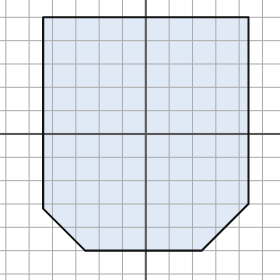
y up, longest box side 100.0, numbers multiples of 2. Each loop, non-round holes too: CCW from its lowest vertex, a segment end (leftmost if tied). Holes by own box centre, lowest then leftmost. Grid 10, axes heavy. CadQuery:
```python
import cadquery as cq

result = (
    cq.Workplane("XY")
    .moveTo(-26.0, -50.0)
    .lineTo(24.0, -50.0)
    .lineTo(44.0, -30.0)
    .lineTo(44.0, 50.0)
    .lineTo(-44.0, 50.0)
    .lineTo(-44.0, -32.0)
    .close()
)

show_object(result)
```